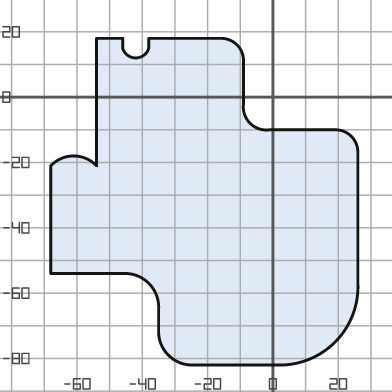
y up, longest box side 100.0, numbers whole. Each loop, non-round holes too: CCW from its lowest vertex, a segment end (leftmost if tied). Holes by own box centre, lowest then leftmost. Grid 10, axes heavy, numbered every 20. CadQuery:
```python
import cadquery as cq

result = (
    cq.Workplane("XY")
    .moveTo(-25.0, -82.0)
    .lineTo(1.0, -82.0)
    .threePointArc((19.0, -75.0), (26.0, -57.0))
    .lineTo(26.0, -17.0)
    .threePointArc((24.0, -12.0), (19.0, -10.0))
    .lineTo(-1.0, -10.0)
    .threePointArc((-7.0, -8.0), (-9.0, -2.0))
    .lineTo(-9.0, 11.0)
    .threePointArc((-11.0, 16.0), (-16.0, 18.0))
    .lineTo(-38.0, 18.0)
    .lineTo(-38.0, 15.0)
    .threePointArc((-42.0, 12.0), (-46.0, 15.0))
    .lineTo(-46.0, 18.0)
    .lineTo(-54.0, 18.0)
    .lineTo(-54.0, -21.0)
    .threePointArc((-61.0, -18.0), (-68.0, -21.0))
    .lineTo(-68.0, -54.0)
    .lineTo(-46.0, -54.0)
    .threePointArc((-38.0, -57.0), (-35.0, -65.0))
    .lineTo(-35.0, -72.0)
    .threePointArc((-32.0, -79.0), (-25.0, -82.0))
    .close()
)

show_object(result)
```